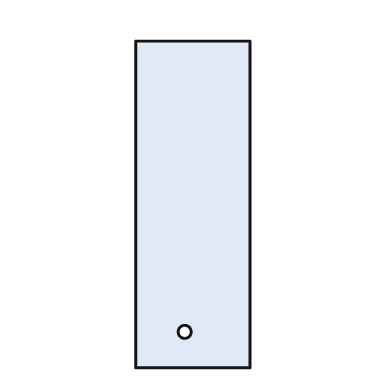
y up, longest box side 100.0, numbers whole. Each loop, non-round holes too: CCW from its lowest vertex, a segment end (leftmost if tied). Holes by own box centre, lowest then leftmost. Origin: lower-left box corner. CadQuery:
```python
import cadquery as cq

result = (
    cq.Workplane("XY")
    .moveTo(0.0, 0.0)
    .lineTo(35.0, 0.0)
    .lineTo(35.0, 100.0)
    .lineTo(0.0, 100.0)
    .close()
    .moveTo(15.0, 11.0)
    .circle(2.0)
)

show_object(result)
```